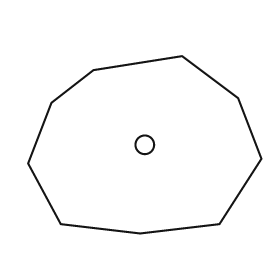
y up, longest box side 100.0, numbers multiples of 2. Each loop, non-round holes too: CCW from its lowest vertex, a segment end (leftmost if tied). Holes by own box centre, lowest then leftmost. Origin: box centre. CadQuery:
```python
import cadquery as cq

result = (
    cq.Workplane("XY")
    .moveTo(-2.0, -38.0)
    .lineTo(32.0, -34.0)
    .lineTo(50.0, -6.0)
    .lineTo(40.0, 20.0)
    .lineTo(16.0, 38.0)
    .lineTo(-22.0, 32.0)
    .lineTo(-40.0, 18.0)
    .lineTo(-50.0, -8.0)
    .lineTo(-36.0, -34.0)
    .close()
    .moveTo(0.0, 0.0)
    .circle(4.0)
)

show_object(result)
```